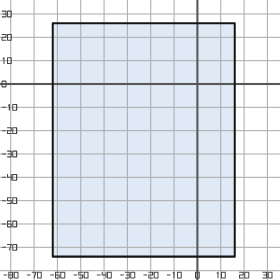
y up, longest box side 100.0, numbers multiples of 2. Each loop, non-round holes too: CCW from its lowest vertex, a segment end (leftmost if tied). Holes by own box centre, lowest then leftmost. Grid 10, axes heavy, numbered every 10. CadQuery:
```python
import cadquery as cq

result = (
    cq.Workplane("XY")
    .moveTo(-62.0, -74.0)
    .lineTo(16.0, -74.0)
    .lineTo(16.0, 26.0)
    .lineTo(-62.0, 26.0)
    .close()
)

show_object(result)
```